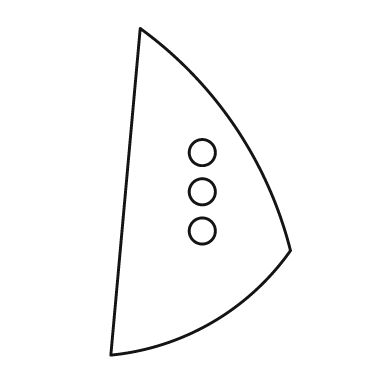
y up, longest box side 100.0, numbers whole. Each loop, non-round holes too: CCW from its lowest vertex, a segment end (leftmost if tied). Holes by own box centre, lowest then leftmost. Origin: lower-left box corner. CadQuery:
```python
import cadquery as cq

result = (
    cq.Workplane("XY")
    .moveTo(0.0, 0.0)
    .threePointArc((31.0, 10.0), (55.0, 32.0))
    .threePointArc((38.0, 70.0), (9.0, 100.0))
    .close()
    .moveTo(28.0, 38.0)
    .circle(4.0)
    .moveTo(28.0, 50.0)
    .circle(4.0)
    .moveTo(28.0, 62.0)
    .circle(4.0)
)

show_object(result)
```